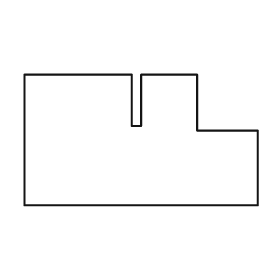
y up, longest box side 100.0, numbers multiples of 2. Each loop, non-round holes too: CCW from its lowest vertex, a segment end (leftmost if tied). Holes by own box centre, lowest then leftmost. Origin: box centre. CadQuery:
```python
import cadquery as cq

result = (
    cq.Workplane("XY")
    .moveTo(-50.0, -28.0)
    .lineTo(50.0, -28.0)
    .lineTo(50.0, 4.0)
    .lineTo(24.0, 4.0)
    .lineTo(24.0, 28.0)
    .lineTo(0.0, 28.0)
    .lineTo(0.0, 6.0)
    .lineTo(-4.0, 6.0)
    .lineTo(-4.0, 28.0)
    .lineTo(-50.0, 28.0)
    .close()
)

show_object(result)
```